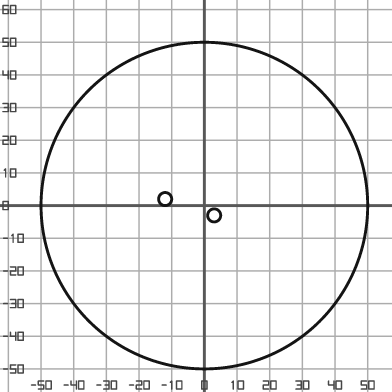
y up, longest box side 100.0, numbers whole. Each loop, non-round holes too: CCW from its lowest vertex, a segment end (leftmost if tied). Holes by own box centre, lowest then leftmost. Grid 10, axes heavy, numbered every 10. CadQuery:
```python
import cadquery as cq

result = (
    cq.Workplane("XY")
    .moveTo(0.0, 0.0)
    .circle(50.0)
    .moveTo(3.0, -3.0)
    .circle(2.0)
    .moveTo(-12.0, 2.0)
    .circle(2.0)
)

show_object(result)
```